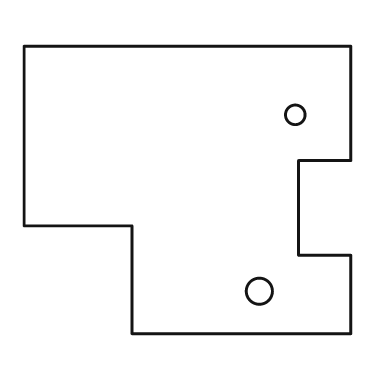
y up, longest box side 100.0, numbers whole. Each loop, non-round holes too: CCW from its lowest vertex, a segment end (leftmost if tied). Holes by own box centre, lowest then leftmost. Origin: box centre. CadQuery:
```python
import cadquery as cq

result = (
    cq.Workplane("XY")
    .moveTo(-17.0, -44.0)
    .lineTo(50.0, -44.0)
    .lineTo(50.0, -20.0)
    .lineTo(34.0, -20.0)
    .lineTo(34.0, 9.0)
    .lineTo(50.0, 9.0)
    .lineTo(50.0, 44.0)
    .lineTo(-50.0, 44.0)
    .lineTo(-50.0, -11.0)
    .lineTo(-17.0, -11.0)
    .close()
    .moveTo(22.0, -31.0)
    .circle(4.0)
    .moveTo(33.0, 23.0)
    .circle(3.0)
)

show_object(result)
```